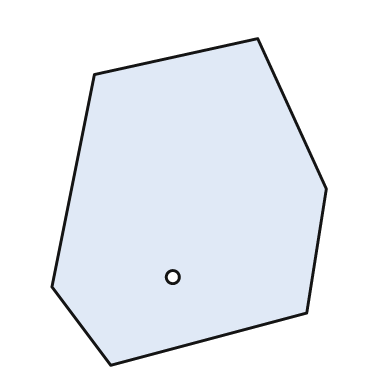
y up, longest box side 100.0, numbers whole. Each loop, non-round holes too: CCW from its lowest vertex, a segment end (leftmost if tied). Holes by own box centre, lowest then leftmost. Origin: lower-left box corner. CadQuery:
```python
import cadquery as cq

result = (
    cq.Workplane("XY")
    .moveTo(18.0, 0.0)
    .lineTo(78.0, 16.0)
    .lineTo(84.0, 54.0)
    .lineTo(63.0, 100.0)
    .lineTo(13.0, 89.0)
    .lineTo(0.0, 24.0)
    .close()
    .moveTo(37.0, 27.0)
    .circle(2.0)
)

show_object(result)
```